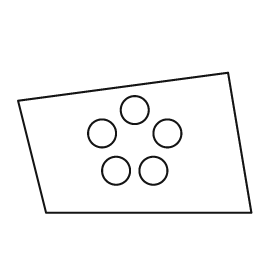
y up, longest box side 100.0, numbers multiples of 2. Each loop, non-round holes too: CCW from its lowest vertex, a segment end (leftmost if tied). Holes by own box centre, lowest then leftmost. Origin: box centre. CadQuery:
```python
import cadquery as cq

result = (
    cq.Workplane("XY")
    .moveTo(-38.0, -30.0)
    .lineTo(50.0, -30.0)
    .lineTo(40.0, 30.0)
    .lineTo(-50.0, 18.0)
    .close()
    .moveTo(-8.0, -12.0)
    .circle(6.0)
    .moveTo(8.0, -12.0)
    .circle(6.0)
    .moveTo(-14.0, 4.0)
    .circle(6.0)
    .moveTo(14.0, 4.0)
    .circle(6.0)
    .moveTo(0.0, 14.0)
    .circle(6.0)
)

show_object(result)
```